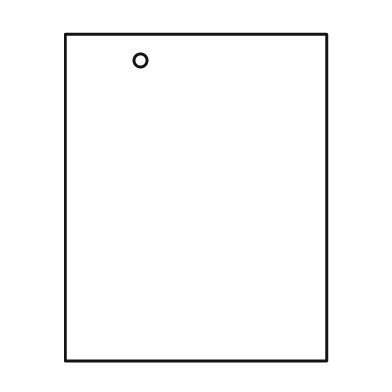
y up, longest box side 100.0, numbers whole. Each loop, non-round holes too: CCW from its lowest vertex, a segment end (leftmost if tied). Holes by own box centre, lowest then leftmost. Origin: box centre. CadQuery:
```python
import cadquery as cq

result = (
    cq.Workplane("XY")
    .moveTo(-40.0, -50.0)
    .lineTo(40.0, -50.0)
    .lineTo(40.0, 50.0)
    .lineTo(-40.0, 50.0)
    .close()
    .moveTo(-17.0, 42.0)
    .circle(2.0)
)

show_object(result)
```